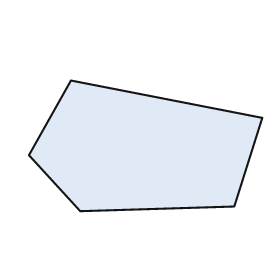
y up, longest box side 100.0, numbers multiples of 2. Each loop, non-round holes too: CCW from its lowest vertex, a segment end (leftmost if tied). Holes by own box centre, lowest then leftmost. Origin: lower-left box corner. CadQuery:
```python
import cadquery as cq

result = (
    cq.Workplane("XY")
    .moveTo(22.0, 0.0)
    .lineTo(88.0, 2.0)
    .lineTo(100.0, 40.0)
    .lineTo(18.0, 56.0)
    .lineTo(0.0, 24.0)
    .close()
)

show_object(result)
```